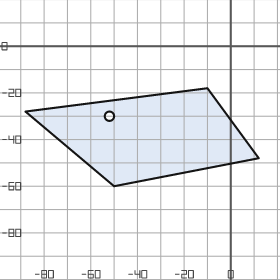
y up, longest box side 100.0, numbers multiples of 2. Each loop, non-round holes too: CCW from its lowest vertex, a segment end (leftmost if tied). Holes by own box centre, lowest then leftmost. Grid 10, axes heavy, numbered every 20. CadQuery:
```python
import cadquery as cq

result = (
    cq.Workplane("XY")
    .moveTo(-50.0, -60.0)
    .lineTo(12.0, -48.0)
    .lineTo(-10.0, -18.0)
    .lineTo(-88.0, -28.0)
    .close()
    .moveTo(-52.0, -30.0)
    .circle(2.0)
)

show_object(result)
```